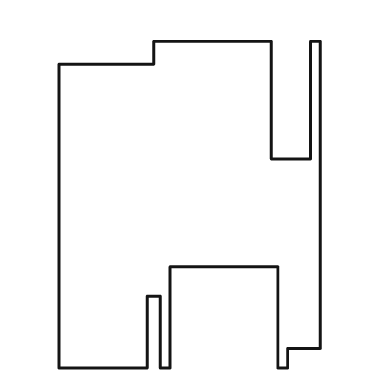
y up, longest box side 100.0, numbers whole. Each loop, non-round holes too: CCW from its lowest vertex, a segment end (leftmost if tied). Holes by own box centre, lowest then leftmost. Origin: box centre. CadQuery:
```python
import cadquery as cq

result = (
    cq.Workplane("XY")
    .moveTo(-40.0, -50.0)
    .lineTo(-13.0, -50.0)
    .lineTo(-13.0, -28.0)
    .lineTo(-9.0, -28.0)
    .lineTo(-9.0, -50.0)
    .lineTo(-6.0, -50.0)
    .lineTo(-6.0, -19.0)
    .lineTo(27.0, -19.0)
    .lineTo(27.0, -50.0)
    .lineTo(30.0, -50.0)
    .lineTo(30.0, -44.0)
    .lineTo(40.0, -44.0)
    .lineTo(40.0, 50.0)
    .lineTo(37.0, 50.0)
    .lineTo(37.0, 14.0)
    .lineTo(25.0, 14.0)
    .lineTo(25.0, 50.0)
    .lineTo(-11.0, 50.0)
    .lineTo(-11.0, 43.0)
    .lineTo(-40.0, 43.0)
    .close()
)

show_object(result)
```